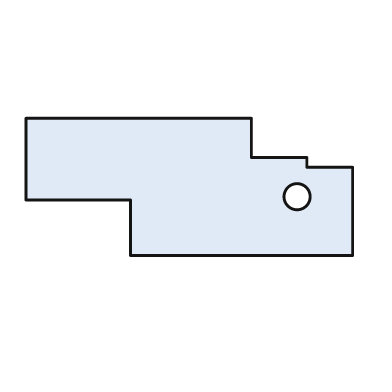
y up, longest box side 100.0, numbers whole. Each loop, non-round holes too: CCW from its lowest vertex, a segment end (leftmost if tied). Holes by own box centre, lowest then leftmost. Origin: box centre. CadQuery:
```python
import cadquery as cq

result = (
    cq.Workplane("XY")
    .moveTo(-18.0, -21.0)
    .lineTo(50.0, -21.0)
    .lineTo(50.0, 6.0)
    .lineTo(36.0, 6.0)
    .lineTo(36.0, 9.0)
    .lineTo(19.0, 9.0)
    .lineTo(19.0, 21.0)
    .lineTo(-50.0, 21.0)
    .lineTo(-50.0, -4.0)
    .lineTo(-18.0, -4.0)
    .close()
    .moveTo(33.0, -3.0)
    .circle(4.0)
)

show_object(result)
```